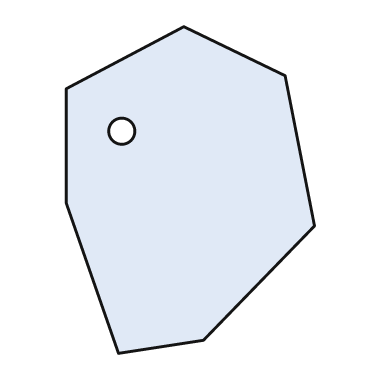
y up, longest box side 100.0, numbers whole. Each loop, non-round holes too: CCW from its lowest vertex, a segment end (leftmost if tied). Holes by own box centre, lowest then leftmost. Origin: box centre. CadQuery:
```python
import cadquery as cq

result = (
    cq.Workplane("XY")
    .moveTo(-22.0, -50.0)
    .lineTo(4.0, -46.0)
    .lineTo(38.0, -11.0)
    .lineTo(29.0, 35.0)
    .lineTo(-2.0, 50.0)
    .lineTo(-38.0, 31.0)
    .lineTo(-38.0, -4.0)
    .close()
    .moveTo(-21.0, 18.0)
    .circle(4.0)
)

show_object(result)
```